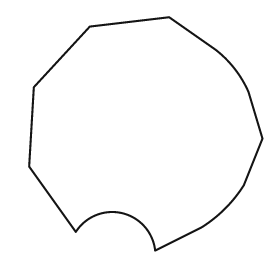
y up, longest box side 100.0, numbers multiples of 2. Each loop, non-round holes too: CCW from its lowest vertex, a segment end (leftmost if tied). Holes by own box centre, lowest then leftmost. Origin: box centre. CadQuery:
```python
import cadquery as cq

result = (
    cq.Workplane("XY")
    .moveTo(4.0, -50.0)
    .lineTo(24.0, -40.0)
    .threePointArc((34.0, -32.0), (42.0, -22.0))
    .lineTo(50.0, -2.0)
    .lineTo(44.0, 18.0)
    .threePointArc((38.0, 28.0), (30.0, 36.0))
    .lineTo(10.0, 50.0)
    .lineTo(-24.0, 46.0)
    .lineTo(-48.0, 20.0)
    .lineTo(-50.0, -14.0)
    .lineTo(-30.0, -42.0)
    .threePointArc((-10.0, -34.0), (4.0, -50.0))
    .close()
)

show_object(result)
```